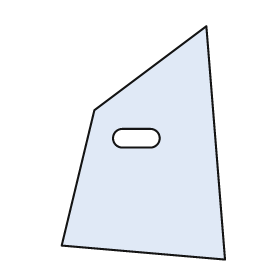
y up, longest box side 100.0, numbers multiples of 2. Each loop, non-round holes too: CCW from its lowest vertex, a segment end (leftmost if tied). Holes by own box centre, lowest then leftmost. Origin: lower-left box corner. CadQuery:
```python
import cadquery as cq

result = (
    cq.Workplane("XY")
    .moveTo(70.0, 0.0)
    .lineTo(62.0, 100.0)
    .lineTo(14.0, 64.0)
    .lineTo(0.0, 6.0)
    .close()
    .moveTo(26.0, 48.0)
    .lineTo(38.0, 48.0)
    .threePointArc((42.0, 52.0), (38.0, 56.0))
    .lineTo(26.0, 56.0)
    .threePointArc((22.0, 52.0), (26.0, 48.0))
    .close()
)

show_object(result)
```